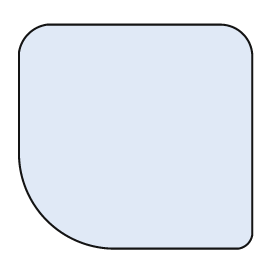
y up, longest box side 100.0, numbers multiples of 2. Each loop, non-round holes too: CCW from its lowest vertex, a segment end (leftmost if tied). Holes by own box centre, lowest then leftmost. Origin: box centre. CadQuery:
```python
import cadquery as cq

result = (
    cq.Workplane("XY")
    .moveTo(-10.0, -48.0)
    .lineTo(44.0, -48.0)
    .threePointArc((48.0, -46.0), (50.0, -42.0))
    .lineTo(50.0, 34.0)
    .threePointArc((46.0, 44.0), (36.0, 48.0))
    .lineTo(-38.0, 48.0)
    .threePointArc((-46.0, 44.0), (-50.0, 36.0))
    .lineTo(-50.0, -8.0)
    .threePointArc((-38.0, -36.0), (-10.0, -48.0))
    .close()
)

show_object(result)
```